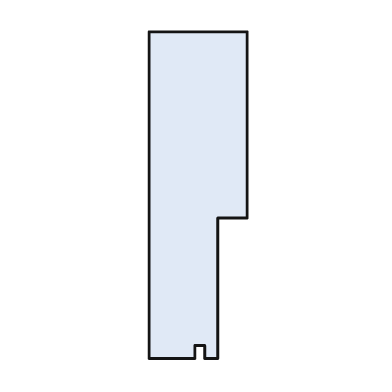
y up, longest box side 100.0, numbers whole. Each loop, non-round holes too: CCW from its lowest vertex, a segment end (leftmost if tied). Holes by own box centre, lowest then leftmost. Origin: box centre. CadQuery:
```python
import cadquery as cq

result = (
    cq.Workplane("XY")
    .moveTo(-15.0, -50.0)
    .lineTo(-1.0, -50.0)
    .lineTo(-1.0, -46.0)
    .lineTo(2.0, -46.0)
    .lineTo(2.0, -50.0)
    .lineTo(6.0, -50.0)
    .lineTo(6.0, -7.0)
    .lineTo(15.0, -7.0)
    .lineTo(15.0, 50.0)
    .lineTo(-15.0, 50.0)
    .close()
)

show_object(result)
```